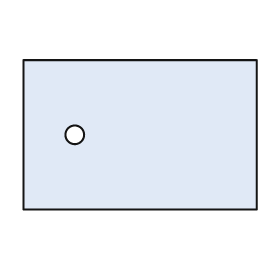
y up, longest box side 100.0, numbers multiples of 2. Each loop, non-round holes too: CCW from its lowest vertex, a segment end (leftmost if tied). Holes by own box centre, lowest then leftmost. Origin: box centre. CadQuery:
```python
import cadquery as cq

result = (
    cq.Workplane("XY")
    .moveTo(-50.0, -32.0)
    .lineTo(50.0, -32.0)
    .lineTo(50.0, 32.0)
    .lineTo(-50.0, 32.0)
    .close()
    .moveTo(-28.0, 0.0)
    .circle(4.0)
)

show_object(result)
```